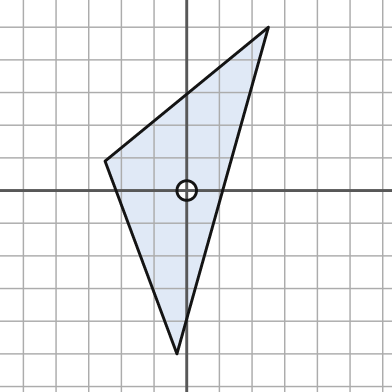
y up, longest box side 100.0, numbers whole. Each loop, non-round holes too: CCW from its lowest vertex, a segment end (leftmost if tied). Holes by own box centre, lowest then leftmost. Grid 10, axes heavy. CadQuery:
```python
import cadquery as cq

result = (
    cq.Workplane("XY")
    .moveTo(-3.0, -50.0)
    .lineTo(25.0, 50.0)
    .lineTo(-25.0, 9.0)
    .close()
    .moveTo(0.0, 0.0)
    .circle(3.0)
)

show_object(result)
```